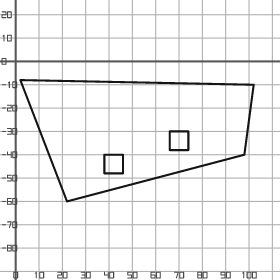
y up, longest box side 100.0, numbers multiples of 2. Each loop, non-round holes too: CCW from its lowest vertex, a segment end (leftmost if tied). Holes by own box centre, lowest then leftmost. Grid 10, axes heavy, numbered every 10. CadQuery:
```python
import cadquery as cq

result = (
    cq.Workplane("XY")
    .moveTo(22.0, -60.0)
    .lineTo(98.0, -40.0)
    .lineTo(102.0, -10.0)
    .lineTo(2.0, -8.0)
    .close()
    .moveTo(38.0, -48.0)
    .lineTo(46.0, -48.0)
    .lineTo(46.0, -40.0)
    .lineTo(38.0, -40.0)
    .close()
    .moveTo(66.0, -38.0)
    .lineTo(74.0, -38.0)
    .lineTo(74.0, -30.0)
    .lineTo(66.0, -30.0)
    .close()
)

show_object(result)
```